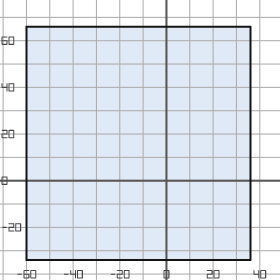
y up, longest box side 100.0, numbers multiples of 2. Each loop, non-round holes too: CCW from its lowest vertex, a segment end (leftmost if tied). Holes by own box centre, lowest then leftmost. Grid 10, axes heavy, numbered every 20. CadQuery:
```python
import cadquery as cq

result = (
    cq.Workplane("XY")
    .moveTo(-60.0, -34.0)
    .lineTo(36.0, -34.0)
    .lineTo(36.0, 66.0)
    .lineTo(-60.0, 66.0)
    .close()
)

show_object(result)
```